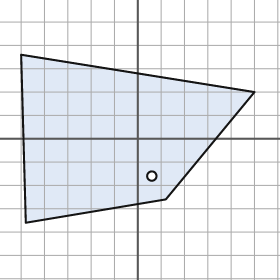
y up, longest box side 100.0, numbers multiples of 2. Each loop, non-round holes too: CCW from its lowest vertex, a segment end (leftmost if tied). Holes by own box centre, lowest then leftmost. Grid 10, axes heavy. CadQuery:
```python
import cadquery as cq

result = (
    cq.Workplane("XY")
    .moveTo(-48.0, -36.0)
    .lineTo(12.0, -26.0)
    .lineTo(50.0, 20.0)
    .lineTo(-50.0, 36.0)
    .close()
    .moveTo(6.0, -16.0)
    .circle(2.0)
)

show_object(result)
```